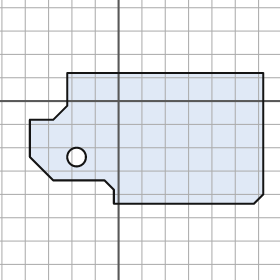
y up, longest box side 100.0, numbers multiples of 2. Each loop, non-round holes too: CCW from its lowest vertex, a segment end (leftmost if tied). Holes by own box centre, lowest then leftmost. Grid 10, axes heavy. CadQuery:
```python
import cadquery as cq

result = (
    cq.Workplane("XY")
    .moveTo(-2.0, -44.0)
    .lineTo(58.0, -44.0)
    .lineTo(62.0, -40.0)
    .lineTo(62.0, 12.0)
    .lineTo(-22.0, 12.0)
    .lineTo(-22.0, -2.0)
    .lineTo(-28.0, -8.0)
    .lineTo(-38.0, -8.0)
    .lineTo(-38.0, -24.0)
    .lineTo(-28.0, -34.0)
    .lineTo(-6.0, -34.0)
    .lineTo(-2.0, -38.0)
    .close()
    .moveTo(-18.0, -24.0)
    .circle(4.0)
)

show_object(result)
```